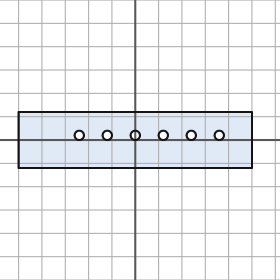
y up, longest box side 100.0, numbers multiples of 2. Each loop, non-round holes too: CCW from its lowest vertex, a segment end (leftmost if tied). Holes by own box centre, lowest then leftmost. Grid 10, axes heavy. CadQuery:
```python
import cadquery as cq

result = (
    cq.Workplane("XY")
    .moveTo(-50.0, -12.0)
    .lineTo(50.0, -12.0)
    .lineTo(50.0, 12.0)
    .lineTo(-50.0, 12.0)
    .close()
    .moveTo(-24.0, 2.0)
    .circle(2.0)
    .moveTo(-12.0, 2.0)
    .circle(2.0)
    .moveTo(0.0, 2.0)
    .circle(2.0)
    .moveTo(12.0, 2.0)
    .circle(2.0)
    .moveTo(24.0, 2.0)
    .circle(2.0)
    .moveTo(36.0, 2.0)
    .circle(2.0)
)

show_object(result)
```